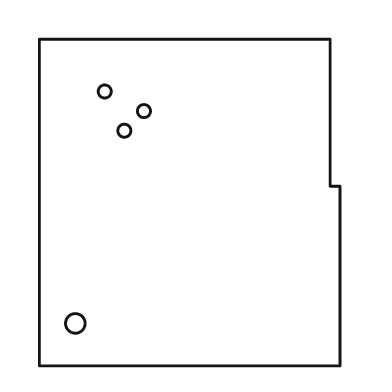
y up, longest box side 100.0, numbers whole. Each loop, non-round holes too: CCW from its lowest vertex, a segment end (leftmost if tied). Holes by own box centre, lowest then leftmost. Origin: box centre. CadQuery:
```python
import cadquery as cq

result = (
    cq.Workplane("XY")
    .moveTo(-46.0, -50.0)
    .lineTo(46.0, -50.0)
    .lineTo(46.0, 5.0)
    .lineTo(43.0, 5.0)
    .lineTo(43.0, 50.0)
    .lineTo(-46.0, 50.0)
    .close()
    .moveTo(-35.0, -37.0)
    .circle(3.0)
    .moveTo(-20.0, 22.0)
    .circle(2.0)
    .moveTo(-14.0, 28.0)
    .circle(2.0)
    .moveTo(-26.0, 34.0)
    .circle(2.0)
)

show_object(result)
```